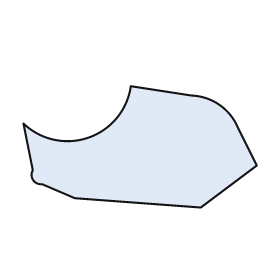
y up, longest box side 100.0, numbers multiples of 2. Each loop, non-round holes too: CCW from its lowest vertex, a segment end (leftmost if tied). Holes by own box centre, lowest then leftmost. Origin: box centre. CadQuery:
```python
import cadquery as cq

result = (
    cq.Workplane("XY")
    .moveTo(26.0, -26.0)
    .lineTo(50.0, -8.0)
    .lineTo(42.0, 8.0)
    .threePointArc((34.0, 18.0), (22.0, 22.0))
    .lineTo(-4.0, 26.0)
    .threePointArc((-22.0, 4.0), (-50.0, 10.0))
    .lineTo(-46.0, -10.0)
    .threePointArc((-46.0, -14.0), (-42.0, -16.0))
    .lineTo(-28.0, -22.0)
    .close()
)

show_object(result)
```